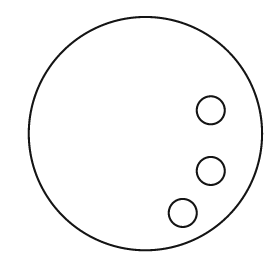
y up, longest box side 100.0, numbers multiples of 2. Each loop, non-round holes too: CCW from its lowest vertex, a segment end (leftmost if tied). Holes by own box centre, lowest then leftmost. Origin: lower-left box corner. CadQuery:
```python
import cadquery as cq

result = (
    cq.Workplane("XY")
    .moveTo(50.0, 50.0)
    .circle(50.0)
    .moveTo(66.0, 16.0)
    .circle(6.0)
    .moveTo(78.0, 34.0)
    .circle(6.0)
    .moveTo(78.0, 60.0)
    .circle(6.0)
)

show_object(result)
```